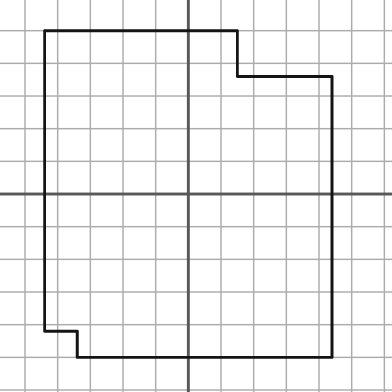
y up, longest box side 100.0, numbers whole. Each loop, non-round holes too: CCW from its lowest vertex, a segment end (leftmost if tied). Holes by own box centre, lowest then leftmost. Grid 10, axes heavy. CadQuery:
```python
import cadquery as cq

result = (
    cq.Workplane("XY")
    .moveTo(-34.0, -50.0)
    .lineTo(44.0, -50.0)
    .lineTo(44.0, 36.0)
    .lineTo(15.0, 36.0)
    .lineTo(15.0, 50.0)
    .lineTo(-44.0, 50.0)
    .lineTo(-44.0, -42.0)
    .lineTo(-34.0, -42.0)
    .close()
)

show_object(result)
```